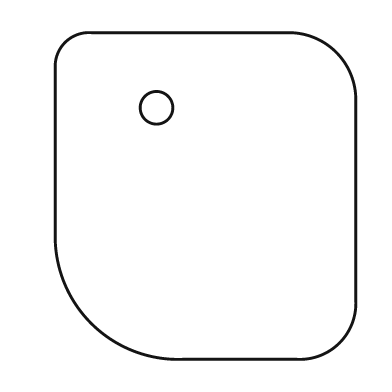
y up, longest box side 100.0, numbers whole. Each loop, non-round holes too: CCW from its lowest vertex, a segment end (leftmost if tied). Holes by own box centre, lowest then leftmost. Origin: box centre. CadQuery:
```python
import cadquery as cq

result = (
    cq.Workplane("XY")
    .moveTo(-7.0, -50.0)
    .lineTo(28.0, -50.0)
    .threePointArc((41.0, -45.0), (46.0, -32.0))
    .lineTo(46.0, 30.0)
    .threePointArc((40.0, 44.0), (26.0, 50.0))
    .lineTo(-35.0, 50.0)
    .threePointArc((-43.0, 47.0), (-46.0, 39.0))
    .lineTo(-46.0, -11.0)
    .threePointArc((-35.0, -39.0), (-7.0, -50.0))
    .close()
    .moveTo(-15.0, 27.0)
    .circle(5.0)
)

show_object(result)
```